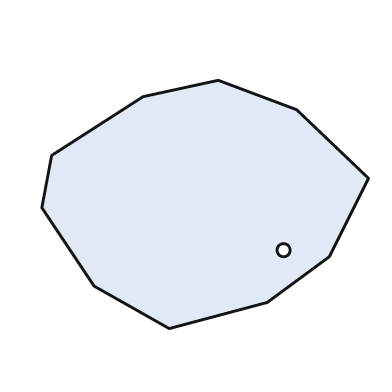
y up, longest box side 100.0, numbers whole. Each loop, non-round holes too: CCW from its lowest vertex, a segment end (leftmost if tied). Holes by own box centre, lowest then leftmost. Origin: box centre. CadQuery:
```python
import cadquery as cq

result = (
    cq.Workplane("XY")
    .moveTo(-11.0, -38.0)
    .lineTo(19.0, -30.0)
    .lineTo(38.0, -16.0)
    .lineTo(50.0, 8.0)
    .lineTo(28.0, 29.0)
    .lineTo(4.0, 38.0)
    .lineTo(-19.0, 33.0)
    .lineTo(-47.0, 15.0)
    .lineTo(-50.0, -1.0)
    .lineTo(-34.0, -25.0)
    .close()
    .moveTo(24.0, -14.0)
    .circle(2.0)
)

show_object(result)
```